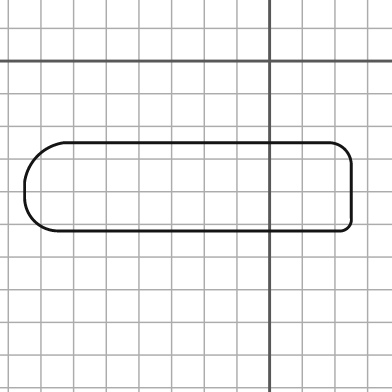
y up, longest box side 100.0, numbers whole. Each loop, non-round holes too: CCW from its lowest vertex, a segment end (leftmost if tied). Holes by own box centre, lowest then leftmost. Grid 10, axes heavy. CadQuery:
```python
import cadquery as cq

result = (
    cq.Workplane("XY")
    .moveTo(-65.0, -52.0)
    .lineTo(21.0, -52.0)
    .threePointArc((24.0, -51.0), (25.0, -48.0))
    .lineTo(25.0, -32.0)
    .threePointArc((23.0, -27.0), (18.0, -25.0))
    .lineTo(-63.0, -25.0)
    .threePointArc((-71.0, -29.0), (-75.0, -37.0))
    .lineTo(-75.0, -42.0)
    .threePointArc((-72.0, -49.0), (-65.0, -52.0))
    .close()
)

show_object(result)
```